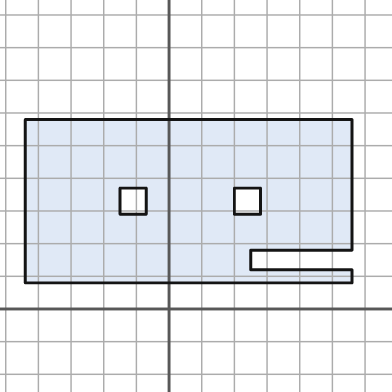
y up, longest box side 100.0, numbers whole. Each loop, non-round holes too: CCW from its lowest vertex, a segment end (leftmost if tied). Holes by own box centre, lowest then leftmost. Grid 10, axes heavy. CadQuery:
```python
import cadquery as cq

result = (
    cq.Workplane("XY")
    .moveTo(-44.0, 8.0)
    .lineTo(56.0, 8.0)
    .lineTo(56.0, 12.0)
    .lineTo(25.0, 12.0)
    .lineTo(25.0, 18.0)
    .lineTo(56.0, 18.0)
    .lineTo(56.0, 58.0)
    .lineTo(-44.0, 58.0)
    .close()
    .moveTo(-15.0, 29.0)
    .lineTo(-7.0, 29.0)
    .lineTo(-7.0, 37.0)
    .lineTo(-15.0, 37.0)
    .close()
    .moveTo(20.0, 29.0)
    .lineTo(28.0, 29.0)
    .lineTo(28.0, 37.0)
    .lineTo(20.0, 37.0)
    .close()
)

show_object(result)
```